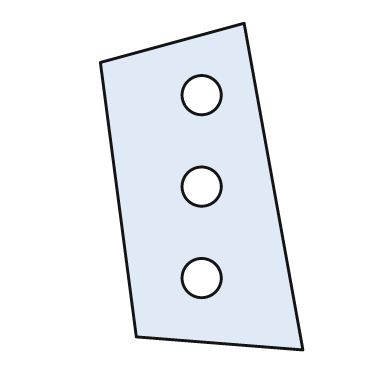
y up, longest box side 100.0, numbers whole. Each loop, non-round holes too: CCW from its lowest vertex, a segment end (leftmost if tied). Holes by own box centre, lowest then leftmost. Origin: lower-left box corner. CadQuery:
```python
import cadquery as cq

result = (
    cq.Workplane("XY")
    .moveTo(62.0, 0.0)
    .lineTo(44.0, 100.0)
    .lineTo(0.0, 88.0)
    .lineTo(11.0, 4.0)
    .close()
    .moveTo(31.0, 22.0)
    .circle(6.0)
    .moveTo(31.0, 50.0)
    .circle(6.0)
    .moveTo(31.0, 78.0)
    .circle(6.0)
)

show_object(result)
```